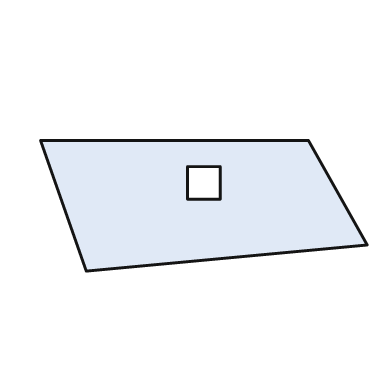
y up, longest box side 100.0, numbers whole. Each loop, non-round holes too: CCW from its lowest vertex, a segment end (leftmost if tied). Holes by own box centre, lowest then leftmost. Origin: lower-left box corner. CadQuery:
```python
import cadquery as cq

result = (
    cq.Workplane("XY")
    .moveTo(14.0, 0.0)
    .lineTo(100.0, 8.0)
    .lineTo(82.0, 40.0)
    .lineTo(0.0, 40.0)
    .close()
    .moveTo(45.0, 22.0)
    .lineTo(55.0, 22.0)
    .lineTo(55.0, 32.0)
    .lineTo(45.0, 32.0)
    .close()
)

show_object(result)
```